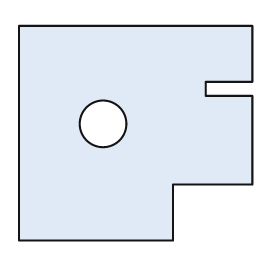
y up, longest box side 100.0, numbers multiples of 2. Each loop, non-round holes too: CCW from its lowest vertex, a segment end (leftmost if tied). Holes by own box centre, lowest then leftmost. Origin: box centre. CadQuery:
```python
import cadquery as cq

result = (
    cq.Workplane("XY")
    .moveTo(-50.0, -46.0)
    .lineTo(16.0, -46.0)
    .lineTo(16.0, -22.0)
    .lineTo(50.0, -22.0)
    .lineTo(50.0, 16.0)
    .lineTo(30.0, 16.0)
    .lineTo(30.0, 22.0)
    .lineTo(50.0, 22.0)
    .lineTo(50.0, 46.0)
    .lineTo(-50.0, 46.0)
    .close()
    .moveTo(-14.0, 4.0)
    .circle(10.0)
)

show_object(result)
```